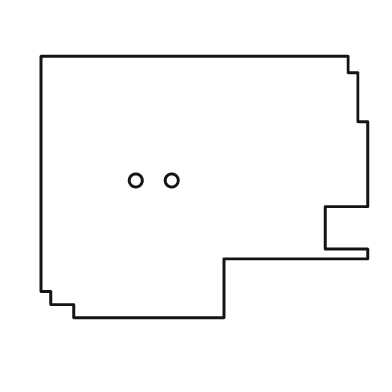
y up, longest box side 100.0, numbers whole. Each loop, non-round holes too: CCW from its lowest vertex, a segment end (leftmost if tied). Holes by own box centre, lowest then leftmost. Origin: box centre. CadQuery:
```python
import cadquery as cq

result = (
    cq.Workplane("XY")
    .moveTo(-40.0, -40.0)
    .lineTo(6.0, -40.0)
    .lineTo(6.0, -22.0)
    .lineTo(50.0, -22.0)
    .lineTo(50.0, -19.0)
    .lineTo(37.0, -19.0)
    .lineTo(37.0, -6.0)
    .lineTo(50.0, -6.0)
    .lineTo(50.0, 20.0)
    .lineTo(47.0, 20.0)
    .lineTo(47.0, 35.0)
    .lineTo(44.0, 35.0)
    .lineTo(44.0, 40.0)
    .lineTo(-50.0, 40.0)
    .lineTo(-50.0, -32.0)
    .lineTo(-47.0, -32.0)
    .lineTo(-47.0, -36.0)
    .lineTo(-40.0, -36.0)
    .close()
    .moveTo(-21.0, 2.0)
    .circle(2.0)
    .moveTo(-10.0, 2.0)
    .circle(2.0)
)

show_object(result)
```